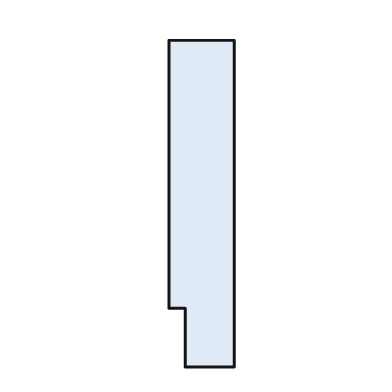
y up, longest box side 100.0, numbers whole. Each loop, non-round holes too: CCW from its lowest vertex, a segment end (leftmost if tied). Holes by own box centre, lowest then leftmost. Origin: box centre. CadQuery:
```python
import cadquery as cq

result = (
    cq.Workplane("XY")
    .moveTo(-5.0, -50.0)
    .lineTo(10.0, -50.0)
    .lineTo(10.0, 50.0)
    .lineTo(-10.0, 50.0)
    .lineTo(-10.0, -32.0)
    .lineTo(-5.0, -32.0)
    .close()
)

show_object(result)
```